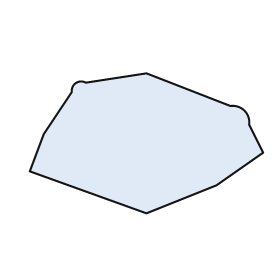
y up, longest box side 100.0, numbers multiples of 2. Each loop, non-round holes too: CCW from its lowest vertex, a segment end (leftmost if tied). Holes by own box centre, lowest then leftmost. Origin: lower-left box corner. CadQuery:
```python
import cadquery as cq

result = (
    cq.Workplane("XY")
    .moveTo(50.0, 0.0)
    .lineTo(80.0, 12.0)
    .lineTo(100.0, 26.0)
    .lineTo(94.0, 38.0)
    .threePointArc((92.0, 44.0), (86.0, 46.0))
    .lineTo(50.0, 60.0)
    .lineTo(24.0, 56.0)
    .threePointArc((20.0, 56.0), (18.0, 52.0))
    .lineTo(6.0, 34.0)
    .lineTo(0.0, 18.0)
    .close()
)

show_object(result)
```